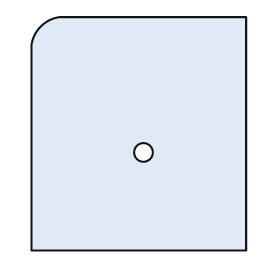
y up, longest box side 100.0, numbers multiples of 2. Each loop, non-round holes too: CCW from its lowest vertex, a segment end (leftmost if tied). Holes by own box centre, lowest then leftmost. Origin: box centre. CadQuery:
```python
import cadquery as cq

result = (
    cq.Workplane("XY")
    .moveTo(-46.0, -50.0)
    .lineTo(46.0, -50.0)
    .lineTo(46.0, 50.0)
    .lineTo(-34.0, 50.0)
    .threePointArc((-42.0, 46.0), (-46.0, 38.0))
    .close()
    .moveTo(2.0, -8.0)
    .circle(4.0)
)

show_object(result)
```